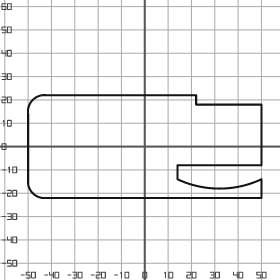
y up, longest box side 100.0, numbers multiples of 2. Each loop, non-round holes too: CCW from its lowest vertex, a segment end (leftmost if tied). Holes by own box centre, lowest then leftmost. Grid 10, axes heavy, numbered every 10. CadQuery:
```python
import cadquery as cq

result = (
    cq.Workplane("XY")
    .moveTo(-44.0, -22.0)
    .lineTo(50.0, -22.0)
    .lineTo(50.0, -14.0)
    .threePointArc((32.0, -18.0), (14.0, -14.0))
    .lineTo(14.0, -8.0)
    .lineTo(50.0, -8.0)
    .lineTo(50.0, 18.0)
    .lineTo(22.0, 18.0)
    .lineTo(22.0, 22.0)
    .lineTo(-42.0, 22.0)
    .threePointArc((-48.0, 20.0), (-50.0, 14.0))
    .lineTo(-50.0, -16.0)
    .threePointArc((-48.0, -20.0), (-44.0, -22.0))
    .close()
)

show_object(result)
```